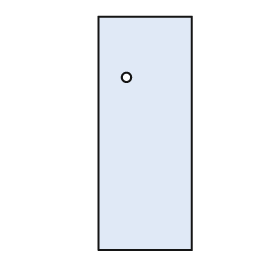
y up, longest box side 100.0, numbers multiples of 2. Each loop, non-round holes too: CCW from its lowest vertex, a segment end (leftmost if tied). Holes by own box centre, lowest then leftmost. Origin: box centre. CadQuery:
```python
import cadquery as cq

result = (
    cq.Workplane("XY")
    .moveTo(-20.0, -50.0)
    .lineTo(20.0, -50.0)
    .lineTo(20.0, 50.0)
    .lineTo(-20.0, 50.0)
    .close()
    .moveTo(-8.0, 24.0)
    .circle(2.0)
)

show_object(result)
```